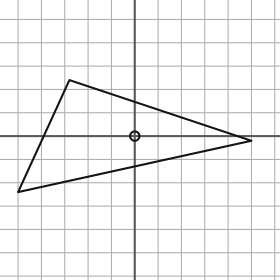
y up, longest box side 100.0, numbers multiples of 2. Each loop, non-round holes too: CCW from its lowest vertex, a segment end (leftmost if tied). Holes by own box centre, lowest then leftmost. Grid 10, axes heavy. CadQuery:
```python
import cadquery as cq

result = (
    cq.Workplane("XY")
    .moveTo(-50.0, -24.0)
    .lineTo(50.0, -2.0)
    .lineTo(-28.0, 24.0)
    .close()
    .moveTo(0.0, 0.0)
    .circle(2.0)
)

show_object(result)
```